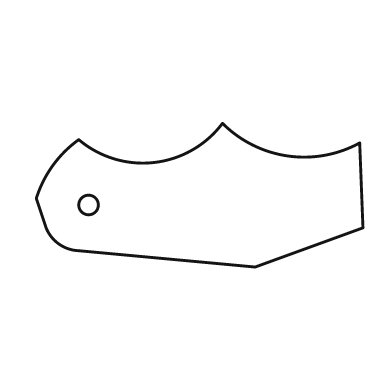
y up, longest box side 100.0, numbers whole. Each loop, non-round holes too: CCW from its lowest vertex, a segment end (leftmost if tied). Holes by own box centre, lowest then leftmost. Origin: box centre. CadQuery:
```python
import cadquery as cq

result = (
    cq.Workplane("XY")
    .moveTo(17.0, -22.0)
    .lineTo(50.0, -10.0)
    .lineTo(49.0, 16.0)
    .threePointArc((27.0, 12.0), (7.0, 22.0))
    .threePointArc((-14.0, 10.0), (-37.0, 17.0))
    .threePointArc((-45.0, 9.0), (-50.0, -1.0))
    .lineTo(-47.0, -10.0)
    .threePointArc((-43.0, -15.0), (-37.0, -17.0))
    .close()
    .moveTo(-34.0, -3.0)
    .circle(3.0)
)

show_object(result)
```